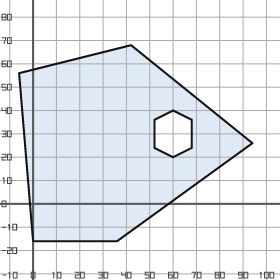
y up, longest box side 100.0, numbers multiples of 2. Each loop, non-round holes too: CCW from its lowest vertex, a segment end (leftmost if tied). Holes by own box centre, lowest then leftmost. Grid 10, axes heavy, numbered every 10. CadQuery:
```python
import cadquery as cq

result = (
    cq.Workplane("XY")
    .moveTo(0.0, -16.0)
    .lineTo(36.0, -16.0)
    .lineTo(94.0, 26.0)
    .lineTo(42.0, 68.0)
    .lineTo(-6.0, 56.0)
    .close()
    .moveTo(60.0, 20.0)
    .lineTo(68.0, 24.0)
    .lineTo(68.0, 36.0)
    .lineTo(60.0, 40.0)
    .lineTo(52.0, 36.0)
    .lineTo(52.0, 24.0)
    .close()
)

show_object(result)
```